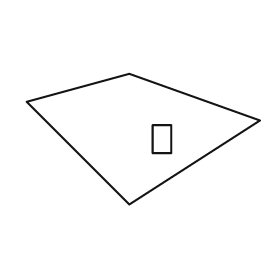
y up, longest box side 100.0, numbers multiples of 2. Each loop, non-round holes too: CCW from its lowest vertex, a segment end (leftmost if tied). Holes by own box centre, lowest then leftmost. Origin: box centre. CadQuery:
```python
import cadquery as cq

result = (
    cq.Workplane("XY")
    .moveTo(-6.0, -28.0)
    .lineTo(50.0, 8.0)
    .lineTo(-6.0, 28.0)
    .lineTo(-50.0, 16.0)
    .close()
    .moveTo(4.0, -6.0)
    .lineTo(12.0, -6.0)
    .lineTo(12.0, 6.0)
    .lineTo(4.0, 6.0)
    .close()
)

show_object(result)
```